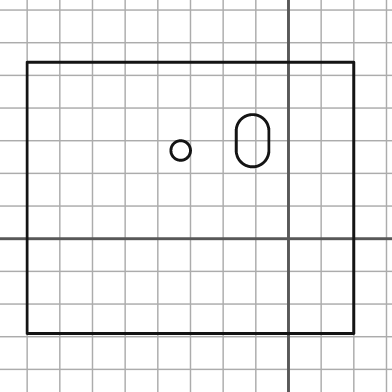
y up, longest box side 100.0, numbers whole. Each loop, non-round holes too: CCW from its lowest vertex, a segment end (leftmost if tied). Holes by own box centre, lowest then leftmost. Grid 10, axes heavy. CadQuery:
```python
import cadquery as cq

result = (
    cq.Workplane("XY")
    .moveTo(-80.0, -29.0)
    .lineTo(20.0, -29.0)
    .lineTo(20.0, 54.0)
    .lineTo(-80.0, 54.0)
    .close()
    .moveTo(-33.0, 27.0)
    .circle(3.0)
    .moveTo(-16.0, 27.0)
    .threePointArc((-11.0, 22.0), (-6.0, 27.0))
    .lineTo(-6.0, 33.0)
    .threePointArc((-11.0, 38.0), (-16.0, 33.0))
    .close()
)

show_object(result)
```